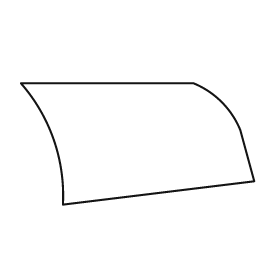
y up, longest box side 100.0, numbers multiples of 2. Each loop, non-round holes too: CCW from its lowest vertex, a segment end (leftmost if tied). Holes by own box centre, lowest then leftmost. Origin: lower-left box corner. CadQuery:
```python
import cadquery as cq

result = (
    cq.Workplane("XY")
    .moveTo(18.0, 0.0)
    .lineTo(100.0, 10.0)
    .lineTo(94.0, 32.0)
    .threePointArc((86.0, 44.0), (74.0, 52.0))
    .lineTo(0.0, 52.0)
    .threePointArc((14.0, 28.0), (18.0, 0.0))
    .close()
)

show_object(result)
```